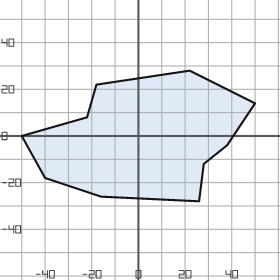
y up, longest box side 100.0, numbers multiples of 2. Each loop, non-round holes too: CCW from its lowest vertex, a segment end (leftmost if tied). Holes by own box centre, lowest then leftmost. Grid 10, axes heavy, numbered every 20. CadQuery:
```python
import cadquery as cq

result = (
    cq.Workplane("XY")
    .moveTo(26.0, -28.0)
    .lineTo(28.0, -12.0)
    .lineTo(38.0, -4.0)
    .lineTo(50.0, 14.0)
    .lineTo(22.0, 28.0)
    .lineTo(-18.0, 22.0)
    .lineTo(-22.0, 8.0)
    .lineTo(-50.0, 0.0)
    .lineTo(-40.0, -18.0)
    .lineTo(-16.0, -26.0)
    .close()
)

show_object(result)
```